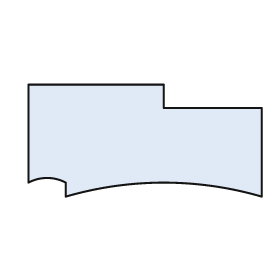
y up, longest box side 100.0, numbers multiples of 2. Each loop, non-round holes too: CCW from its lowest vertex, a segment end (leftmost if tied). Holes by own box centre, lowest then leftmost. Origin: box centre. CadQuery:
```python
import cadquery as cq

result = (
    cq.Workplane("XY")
    .moveTo(-34.0, -24.0)
    .threePointArc((8.0, -18.0), (50.0, -24.0))
    .lineTo(50.0, 14.0)
    .lineTo(8.0, 14.0)
    .lineTo(8.0, 24.0)
    .lineTo(-50.0, 24.0)
    .lineTo(-50.0, -18.0)
    .threePointArc((-42.0, -16.0), (-34.0, -18.0))
    .close()
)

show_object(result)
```